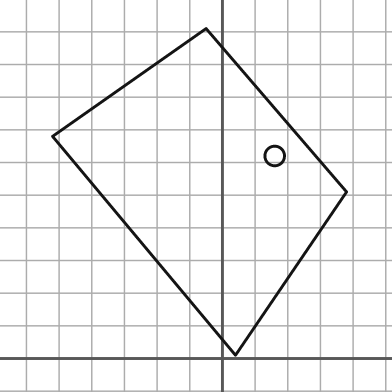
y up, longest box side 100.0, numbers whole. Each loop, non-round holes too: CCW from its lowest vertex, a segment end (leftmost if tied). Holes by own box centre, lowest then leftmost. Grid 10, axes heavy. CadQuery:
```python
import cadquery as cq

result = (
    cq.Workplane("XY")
    .moveTo(4.0, 1.0)
    .lineTo(38.0, 51.0)
    .lineTo(-5.0, 101.0)
    .lineTo(-52.0, 68.0)
    .close()
    .moveTo(16.0, 62.0)
    .circle(3.0)
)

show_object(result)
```